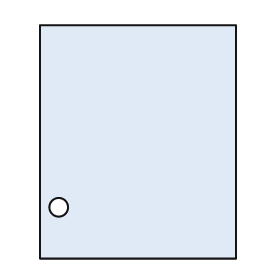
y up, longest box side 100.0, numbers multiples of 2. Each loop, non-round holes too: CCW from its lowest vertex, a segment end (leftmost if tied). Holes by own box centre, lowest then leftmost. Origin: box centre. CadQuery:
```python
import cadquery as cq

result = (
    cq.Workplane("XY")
    .moveTo(-42.0, -50.0)
    .lineTo(42.0, -50.0)
    .lineTo(42.0, 50.0)
    .lineTo(-42.0, 50.0)
    .close()
    .moveTo(-34.0, -28.0)
    .circle(4.0)
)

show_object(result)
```